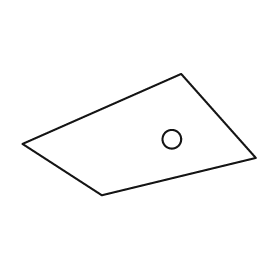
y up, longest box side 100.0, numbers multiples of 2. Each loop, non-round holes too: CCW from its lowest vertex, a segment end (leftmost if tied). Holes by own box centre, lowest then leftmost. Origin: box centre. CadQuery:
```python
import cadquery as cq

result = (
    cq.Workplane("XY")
    .moveTo(-16.0, -26.0)
    .lineTo(50.0, -10.0)
    .lineTo(18.0, 26.0)
    .lineTo(-50.0, -4.0)
    .close()
    .moveTo(14.0, -2.0)
    .circle(4.0)
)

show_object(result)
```